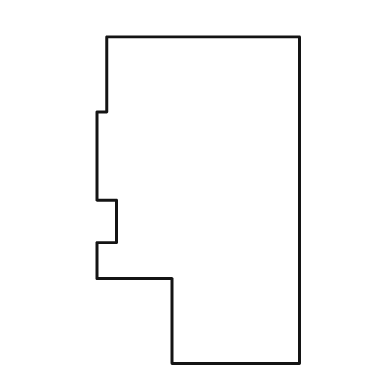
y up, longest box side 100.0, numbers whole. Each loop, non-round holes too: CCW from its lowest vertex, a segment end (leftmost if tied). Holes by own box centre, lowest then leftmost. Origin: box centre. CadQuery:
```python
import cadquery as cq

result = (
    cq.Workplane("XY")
    .moveTo(-8.0, -50.0)
    .lineTo(31.0, -50.0)
    .lineTo(31.0, 50.0)
    .lineTo(-28.0, 50.0)
    .lineTo(-28.0, 27.0)
    .lineTo(-31.0, 27.0)
    .lineTo(-31.0, 0.0)
    .lineTo(-25.0, 0.0)
    .lineTo(-25.0, -13.0)
    .lineTo(-31.0, -13.0)
    .lineTo(-31.0, -24.0)
    .lineTo(-8.0, -24.0)
    .close()
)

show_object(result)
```